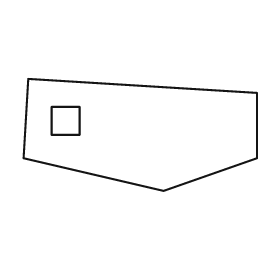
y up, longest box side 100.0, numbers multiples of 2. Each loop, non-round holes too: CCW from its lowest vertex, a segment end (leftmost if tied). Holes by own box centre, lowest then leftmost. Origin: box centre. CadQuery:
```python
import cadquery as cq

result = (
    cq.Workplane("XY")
    .moveTo(10.0, -24.0)
    .lineTo(50.0, -10.0)
    .lineTo(50.0, 18.0)
    .lineTo(-48.0, 24.0)
    .lineTo(-50.0, -10.0)
    .close()
    .moveTo(-38.0, 0.0)
    .lineTo(-26.0, 0.0)
    .lineTo(-26.0, 12.0)
    .lineTo(-38.0, 12.0)
    .close()
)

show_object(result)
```